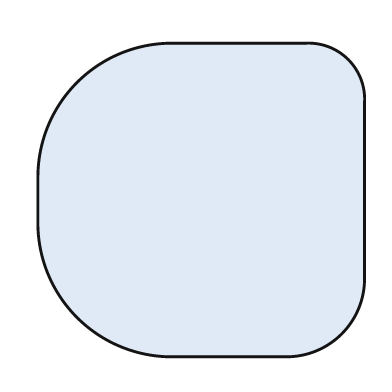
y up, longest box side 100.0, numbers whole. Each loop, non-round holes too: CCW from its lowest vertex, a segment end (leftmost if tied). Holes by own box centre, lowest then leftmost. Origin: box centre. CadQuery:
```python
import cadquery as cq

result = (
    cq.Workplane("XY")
    .moveTo(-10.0, -48.0)
    .lineTo(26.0, -48.0)
    .threePointArc((43.0, -41.0), (50.0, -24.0))
    .lineTo(50.0, 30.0)
    .threePointArc((45.0, 43.0), (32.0, 48.0))
    .lineTo(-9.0, 48.0)
    .threePointArc((-38.0, 36.0), (-50.0, 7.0))
    .lineTo(-50.0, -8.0)
    .threePointArc((-38.0, -36.0), (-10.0, -48.0))
    .close()
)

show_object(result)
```